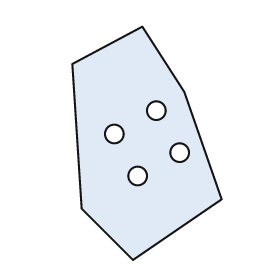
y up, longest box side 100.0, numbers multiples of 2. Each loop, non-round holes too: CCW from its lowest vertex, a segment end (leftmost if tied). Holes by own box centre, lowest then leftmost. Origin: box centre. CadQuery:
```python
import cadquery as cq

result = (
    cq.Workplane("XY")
    .moveTo(-6.0, -50.0)
    .lineTo(32.0, -24.0)
    .lineTo(16.0, 22.0)
    .lineTo(-2.0, 50.0)
    .lineTo(-32.0, 34.0)
    .lineTo(-28.0, -28.0)
    .close()
    .moveTo(-4.0, -14.0)
    .circle(4.0)
    .moveTo(14.0, -4.0)
    .circle(4.0)
    .moveTo(-14.0, 4.0)
    .circle(4.0)
    .moveTo(4.0, 14.0)
    .circle(4.0)
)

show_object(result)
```